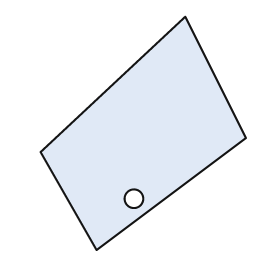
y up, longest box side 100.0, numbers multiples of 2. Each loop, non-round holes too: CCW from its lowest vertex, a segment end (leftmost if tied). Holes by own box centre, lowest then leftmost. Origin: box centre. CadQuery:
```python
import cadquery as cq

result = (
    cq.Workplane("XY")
    .moveTo(-20.0, -50.0)
    .lineTo(44.0, -2.0)
    .lineTo(18.0, 50.0)
    .lineTo(-44.0, -8.0)
    .close()
    .moveTo(-4.0, -28.0)
    .circle(4.0)
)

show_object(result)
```